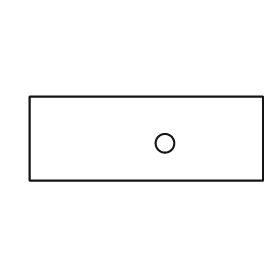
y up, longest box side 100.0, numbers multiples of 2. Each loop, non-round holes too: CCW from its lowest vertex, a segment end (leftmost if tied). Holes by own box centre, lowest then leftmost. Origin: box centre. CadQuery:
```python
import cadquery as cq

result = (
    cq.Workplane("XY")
    .moveTo(-50.0, -18.0)
    .lineTo(50.0, -18.0)
    .lineTo(50.0, 18.0)
    .lineTo(-50.0, 18.0)
    .close()
    .moveTo(8.0, -2.0)
    .circle(4.0)
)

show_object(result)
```